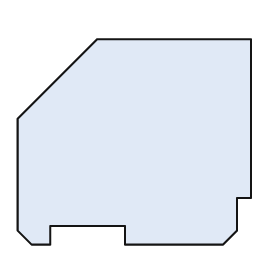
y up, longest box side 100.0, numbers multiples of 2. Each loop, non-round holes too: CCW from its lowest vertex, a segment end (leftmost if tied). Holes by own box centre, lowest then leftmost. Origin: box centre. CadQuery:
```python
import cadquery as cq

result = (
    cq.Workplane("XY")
    .moveTo(-44.0, -44.0)
    .lineTo(-36.0, -44.0)
    .lineTo(-36.0, -36.0)
    .lineTo(-4.0, -36.0)
    .lineTo(-4.0, -44.0)
    .lineTo(38.0, -44.0)
    .lineTo(44.0, -38.0)
    .lineTo(44.0, -24.0)
    .lineTo(50.0, -24.0)
    .lineTo(50.0, 44.0)
    .lineTo(-16.0, 44.0)
    .lineTo(-50.0, 10.0)
    .lineTo(-50.0, -38.0)
    .close()
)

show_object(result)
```